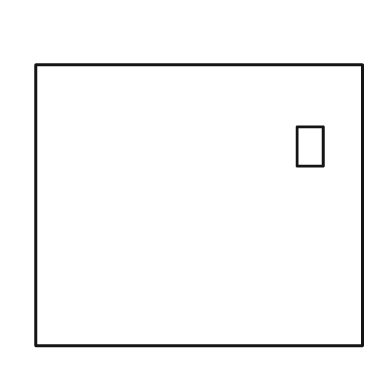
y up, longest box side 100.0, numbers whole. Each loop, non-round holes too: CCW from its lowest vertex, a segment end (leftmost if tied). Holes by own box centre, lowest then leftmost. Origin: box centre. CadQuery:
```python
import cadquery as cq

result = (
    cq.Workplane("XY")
    .moveTo(-50.0, -43.0)
    .lineTo(50.0, -43.0)
    .lineTo(50.0, 43.0)
    .lineTo(-50.0, 43.0)
    .close()
    .moveTo(30.0, 12.0)
    .lineTo(38.0, 12.0)
    .lineTo(38.0, 24.0)
    .lineTo(30.0, 24.0)
    .close()
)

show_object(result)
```